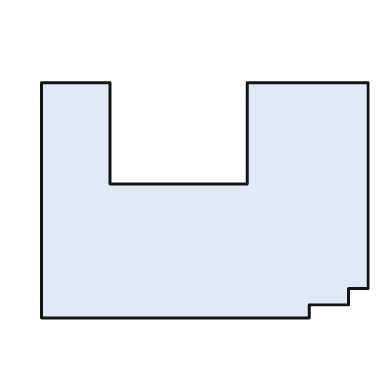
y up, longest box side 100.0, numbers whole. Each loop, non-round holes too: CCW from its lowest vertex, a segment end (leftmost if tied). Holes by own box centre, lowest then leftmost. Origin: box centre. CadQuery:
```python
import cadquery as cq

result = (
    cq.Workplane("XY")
    .moveTo(-50.0, -36.0)
    .lineTo(32.0, -36.0)
    .lineTo(32.0, -32.0)
    .lineTo(44.0, -32.0)
    .lineTo(44.0, -27.0)
    .lineTo(50.0, -27.0)
    .lineTo(50.0, 36.0)
    .lineTo(13.0, 36.0)
    .lineTo(13.0, 5.0)
    .lineTo(-29.0, 5.0)
    .lineTo(-29.0, 36.0)
    .lineTo(-50.0, 36.0)
    .close()
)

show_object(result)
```